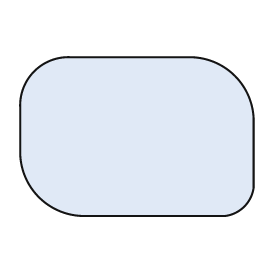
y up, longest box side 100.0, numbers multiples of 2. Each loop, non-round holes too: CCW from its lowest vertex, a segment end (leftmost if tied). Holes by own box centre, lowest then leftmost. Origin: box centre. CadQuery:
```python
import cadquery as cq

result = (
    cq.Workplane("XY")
    .moveTo(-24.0, -34.0)
    .lineTo(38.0, -34.0)
    .threePointArc((46.0, -30.0), (50.0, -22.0))
    .lineTo(50.0, 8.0)
    .threePointArc((42.0, 26.0), (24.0, 34.0))
    .lineTo(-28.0, 34.0)
    .threePointArc((-44.0, 28.0), (-50.0, 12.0))
    .lineTo(-50.0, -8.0)
    .threePointArc((-42.0, -26.0), (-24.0, -34.0))
    .close()
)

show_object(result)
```